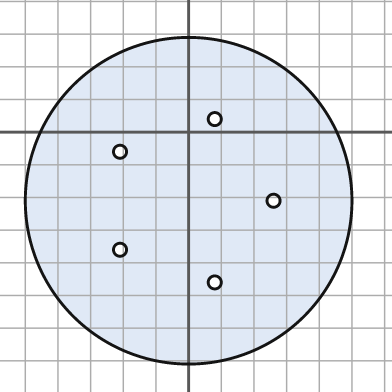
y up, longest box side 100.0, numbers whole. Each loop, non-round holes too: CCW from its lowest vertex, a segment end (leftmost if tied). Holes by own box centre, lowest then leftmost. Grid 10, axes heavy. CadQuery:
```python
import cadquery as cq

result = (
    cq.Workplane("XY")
    .moveTo(0.0, -21.0)
    .circle(50.0)
    .moveTo(8.0, -46.0)
    .circle(2.0)
    .moveTo(-21.0, -36.0)
    .circle(2.0)
    .moveTo(26.0, -21.0)
    .circle(2.0)
    .moveTo(-21.0, -6.0)
    .circle(2.0)
    .moveTo(8.0, 4.0)
    .circle(2.0)
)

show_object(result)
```